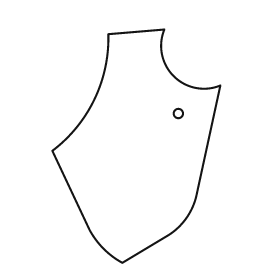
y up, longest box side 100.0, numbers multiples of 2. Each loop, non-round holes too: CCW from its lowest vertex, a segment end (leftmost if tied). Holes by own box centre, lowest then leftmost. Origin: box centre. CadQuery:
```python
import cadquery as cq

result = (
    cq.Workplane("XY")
    .moveTo(-6.0, -50.0)
    .lineTo(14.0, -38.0)
    .threePointArc((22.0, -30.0), (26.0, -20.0))
    .lineTo(36.0, 26.0)
    .threePointArc((16.0, 30.0), (12.0, 50.0))
    .lineTo(-12.0, 48.0)
    .threePointArc((-18.0, 20.0), (-36.0, -2.0))
    .lineTo(-20.0, -36.0)
    .threePointArc((-14.0, -44.0), (-6.0, -50.0))
    .close()
    .moveTo(18.0, 14.0)
    .circle(2.0)
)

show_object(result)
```